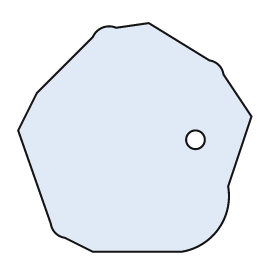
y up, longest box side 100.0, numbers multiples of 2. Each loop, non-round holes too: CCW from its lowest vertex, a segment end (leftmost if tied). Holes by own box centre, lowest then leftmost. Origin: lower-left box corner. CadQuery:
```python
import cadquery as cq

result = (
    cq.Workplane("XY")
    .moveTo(32.0, 0.0)
    .lineTo(70.0, 0.0)
    .threePointArc((86.0, 10.0), (90.0, 28.0))
    .lineTo(100.0, 58.0)
    .lineTo(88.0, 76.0)
    .threePointArc((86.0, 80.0), (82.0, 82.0))
    .lineTo(56.0, 98.0)
    .lineTo(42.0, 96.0)
    .threePointArc((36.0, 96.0), (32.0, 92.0))
    .lineTo(8.0, 68.0)
    .lineTo(0.0, 52.0)
    .lineTo(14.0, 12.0)
    .threePointArc((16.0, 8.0), (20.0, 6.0))
    .close()
    .moveTo(76.0, 48.0)
    .circle(4.0)
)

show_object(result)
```